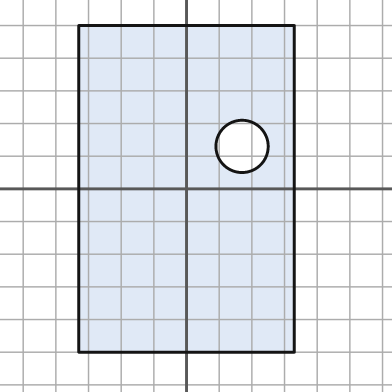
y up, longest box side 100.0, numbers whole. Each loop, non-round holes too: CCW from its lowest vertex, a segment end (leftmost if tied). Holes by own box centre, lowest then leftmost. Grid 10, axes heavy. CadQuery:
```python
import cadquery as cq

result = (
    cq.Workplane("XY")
    .moveTo(-33.0, -50.0)
    .lineTo(33.0, -50.0)
    .lineTo(33.0, 50.0)
    .lineTo(-33.0, 50.0)
    .close()
    .moveTo(17.0, 13.0)
    .circle(8.0)
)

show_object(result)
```